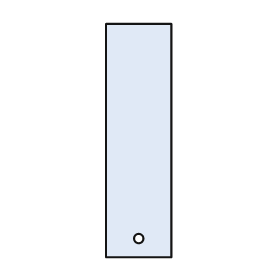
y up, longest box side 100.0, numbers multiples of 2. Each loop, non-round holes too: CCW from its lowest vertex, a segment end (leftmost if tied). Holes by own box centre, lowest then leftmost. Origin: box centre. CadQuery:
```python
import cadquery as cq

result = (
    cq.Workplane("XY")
    .moveTo(-14.0, -50.0)
    .lineTo(14.0, -50.0)
    .lineTo(14.0, 50.0)
    .lineTo(-14.0, 50.0)
    .close()
    .moveTo(0.0, -42.0)
    .circle(2.0)
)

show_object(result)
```